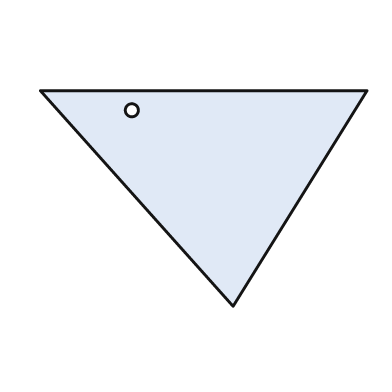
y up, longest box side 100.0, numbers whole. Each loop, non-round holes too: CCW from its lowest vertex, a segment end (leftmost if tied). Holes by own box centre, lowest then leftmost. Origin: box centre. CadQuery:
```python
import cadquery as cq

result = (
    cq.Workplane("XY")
    .moveTo(9.0, -33.0)
    .lineTo(50.0, 33.0)
    .lineTo(-50.0, 33.0)
    .close()
    .moveTo(-22.0, 27.0)
    .circle(2.0)
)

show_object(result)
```